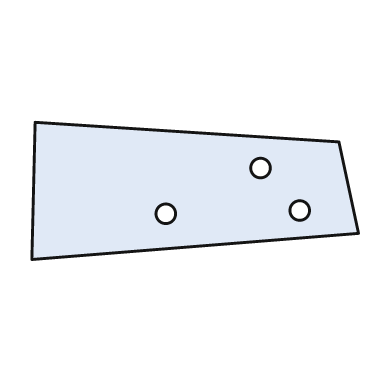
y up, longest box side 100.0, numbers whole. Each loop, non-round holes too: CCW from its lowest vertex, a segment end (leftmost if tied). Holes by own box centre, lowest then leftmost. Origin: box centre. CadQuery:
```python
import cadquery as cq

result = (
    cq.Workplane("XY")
    .moveTo(-50.0, -21.0)
    .lineTo(50.0, -13.0)
    .lineTo(44.0, 15.0)
    .lineTo(-49.0, 21.0)
    .close()
    .moveTo(-9.0, -7.0)
    .circle(3.0)
    .moveTo(32.0, -6.0)
    .circle(3.0)
    .moveTo(20.0, 7.0)
    .circle(3.0)
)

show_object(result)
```